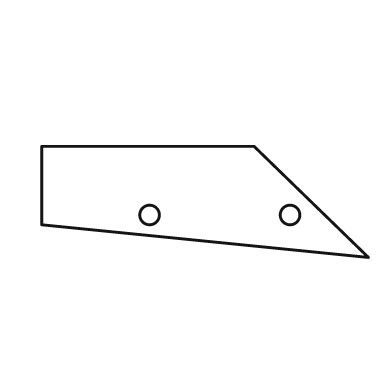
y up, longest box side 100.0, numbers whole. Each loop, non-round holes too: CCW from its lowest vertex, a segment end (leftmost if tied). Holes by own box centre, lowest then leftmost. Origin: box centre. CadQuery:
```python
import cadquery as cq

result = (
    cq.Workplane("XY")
    .moveTo(50.0, -17.0)
    .lineTo(15.0, 17.0)
    .lineTo(-50.0, 17.0)
    .lineTo(-50.0, -7.0)
    .close()
    .moveTo(-17.0, -4.0)
    .circle(3.0)
    .moveTo(26.0, -4.0)
    .circle(3.0)
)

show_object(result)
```